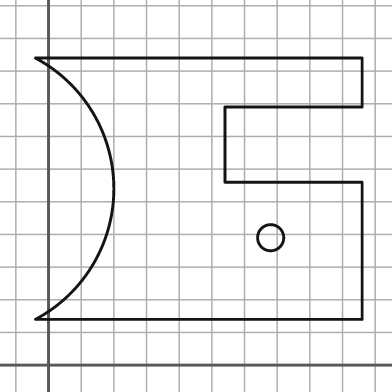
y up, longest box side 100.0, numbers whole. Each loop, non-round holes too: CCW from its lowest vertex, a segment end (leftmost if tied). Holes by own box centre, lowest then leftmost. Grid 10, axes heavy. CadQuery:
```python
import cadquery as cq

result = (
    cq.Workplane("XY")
    .moveTo(-4.0, 14.0)
    .lineTo(96.0, 14.0)
    .lineTo(96.0, 56.0)
    .lineTo(54.0, 56.0)
    .lineTo(54.0, 79.0)
    .lineTo(96.0, 79.0)
    .lineTo(96.0, 94.0)
    .lineTo(-4.0, 94.0)
    .threePointArc((20.0, 54.0), (-4.0, 14.0))
    .close()
    .moveTo(68.0, 39.0)
    .circle(4.0)
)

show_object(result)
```